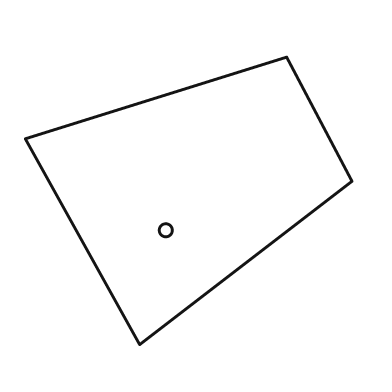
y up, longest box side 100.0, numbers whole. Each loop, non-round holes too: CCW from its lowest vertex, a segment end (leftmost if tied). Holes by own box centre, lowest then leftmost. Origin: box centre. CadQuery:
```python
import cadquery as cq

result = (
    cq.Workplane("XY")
    .moveTo(-15.0, -44.0)
    .lineTo(50.0, 6.0)
    .lineTo(30.0, 44.0)
    .lineTo(-50.0, 19.0)
    .close()
    .moveTo(-7.0, -9.0)
    .circle(2.0)
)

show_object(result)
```